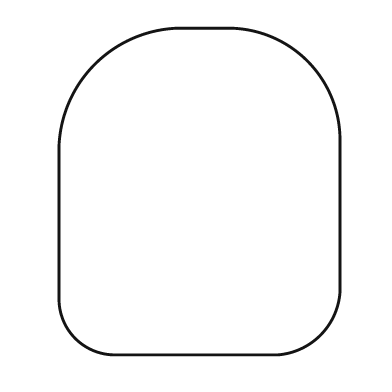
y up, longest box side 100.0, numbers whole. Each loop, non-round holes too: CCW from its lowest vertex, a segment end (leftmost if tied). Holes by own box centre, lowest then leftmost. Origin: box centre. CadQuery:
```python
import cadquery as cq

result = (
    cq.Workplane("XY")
    .moveTo(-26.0, -50.0)
    .lineTo(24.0, -50.0)
    .threePointArc((37.0, -44.0), (43.0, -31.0))
    .lineTo(43.0, 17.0)
    .threePointArc((33.0, 40.0), (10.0, 50.0))
    .lineTo(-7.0, 50.0)
    .threePointArc((-32.0, 39.0), (-43.0, 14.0))
    .lineTo(-43.0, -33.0)
    .threePointArc((-38.0, -45.0), (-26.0, -50.0))
    .close()
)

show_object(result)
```